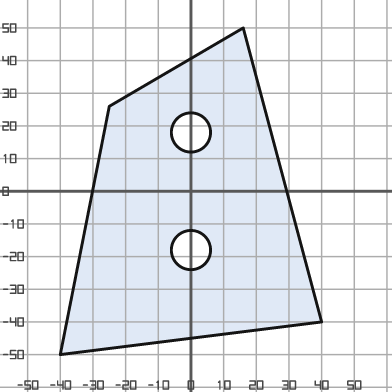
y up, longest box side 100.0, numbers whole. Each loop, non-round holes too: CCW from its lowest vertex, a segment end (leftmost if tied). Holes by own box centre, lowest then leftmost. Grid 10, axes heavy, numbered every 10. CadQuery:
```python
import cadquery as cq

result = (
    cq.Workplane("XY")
    .moveTo(-40.0, -50.0)
    .lineTo(40.0, -40.0)
    .lineTo(16.0, 50.0)
    .lineTo(-25.0, 26.0)
    .close()
    .moveTo(0.0, -18.0)
    .circle(6.0)
    .moveTo(0.0, 18.0)
    .circle(6.0)
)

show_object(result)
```